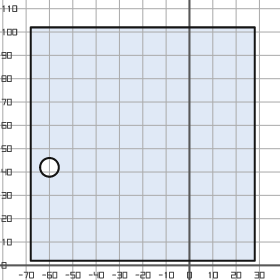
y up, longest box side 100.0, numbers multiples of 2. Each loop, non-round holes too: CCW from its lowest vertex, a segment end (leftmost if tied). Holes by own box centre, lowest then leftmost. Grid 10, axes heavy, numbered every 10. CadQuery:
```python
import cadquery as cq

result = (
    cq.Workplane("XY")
    .moveTo(-68.0, 2.0)
    .lineTo(28.0, 2.0)
    .lineTo(28.0, 102.0)
    .lineTo(-68.0, 102.0)
    .close()
    .moveTo(-60.0, 42.0)
    .circle(4.0)
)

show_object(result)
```